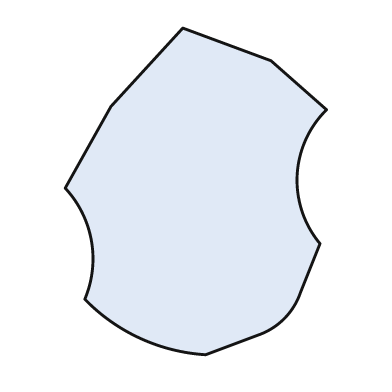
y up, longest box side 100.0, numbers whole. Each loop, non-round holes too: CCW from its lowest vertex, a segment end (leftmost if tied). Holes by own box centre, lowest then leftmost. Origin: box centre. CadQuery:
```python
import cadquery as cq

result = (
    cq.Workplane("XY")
    .moveTo(3.0, -50.0)
    .lineTo(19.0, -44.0)
    .threePointArc((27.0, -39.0), (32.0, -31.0))
    .lineTo(38.0, -16.0)
    .threePointArc((31.0, 5.0), (40.0, 25.0))
    .lineTo(23.0, 40.0)
    .lineTo(-4.0, 50.0)
    .lineTo(-26.0, 26.0)
    .lineTo(-40.0, 1.0)
    .threePointArc((-32.0, -15.0), (-34.0, -33.0))
    .threePointArc((-17.0, -45.0), (3.0, -50.0))
    .close()
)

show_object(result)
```